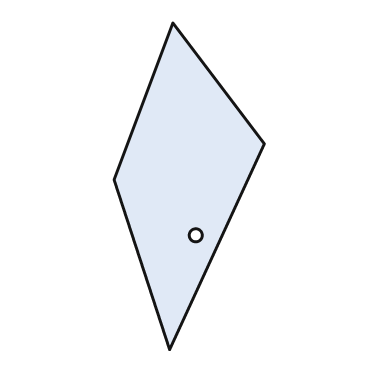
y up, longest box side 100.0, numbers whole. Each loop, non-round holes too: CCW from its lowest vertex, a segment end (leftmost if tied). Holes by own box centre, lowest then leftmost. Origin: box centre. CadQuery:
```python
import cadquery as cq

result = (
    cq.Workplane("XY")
    .moveTo(-6.0, -50.0)
    .lineTo(23.0, 13.0)
    .lineTo(-5.0, 50.0)
    .lineTo(-23.0, 2.0)
    .close()
    .moveTo(2.0, -15.0)
    .circle(2.0)
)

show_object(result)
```